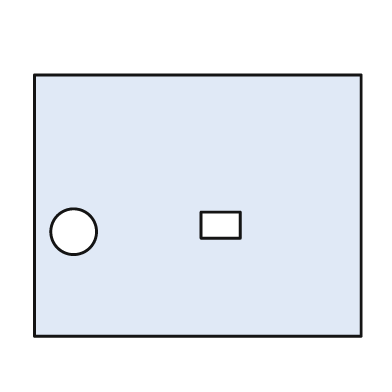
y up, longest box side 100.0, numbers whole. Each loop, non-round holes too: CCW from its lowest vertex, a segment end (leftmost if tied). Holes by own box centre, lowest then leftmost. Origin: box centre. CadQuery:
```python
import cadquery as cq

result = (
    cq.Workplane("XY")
    .moveTo(-50.0, -40.0)
    .lineTo(50.0, -40.0)
    .lineTo(50.0, 40.0)
    .lineTo(-50.0, 40.0)
    .close()
    .moveTo(-38.0, -8.0)
    .circle(7.0)
    .moveTo(1.0, -10.0)
    .lineTo(13.0, -10.0)
    .lineTo(13.0, -2.0)
    .lineTo(1.0, -2.0)
    .close()
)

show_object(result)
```